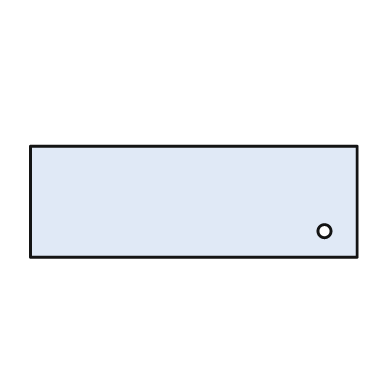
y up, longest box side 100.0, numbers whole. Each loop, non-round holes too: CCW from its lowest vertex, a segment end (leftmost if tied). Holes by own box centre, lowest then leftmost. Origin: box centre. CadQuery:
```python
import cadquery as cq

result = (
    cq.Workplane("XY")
    .moveTo(-50.0, -17.0)
    .lineTo(50.0, -17.0)
    .lineTo(50.0, 17.0)
    .lineTo(-50.0, 17.0)
    .close()
    .moveTo(40.0, -9.0)
    .circle(2.0)
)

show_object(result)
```